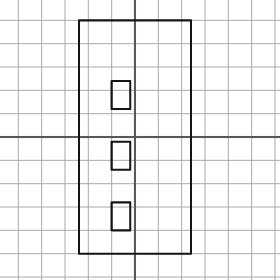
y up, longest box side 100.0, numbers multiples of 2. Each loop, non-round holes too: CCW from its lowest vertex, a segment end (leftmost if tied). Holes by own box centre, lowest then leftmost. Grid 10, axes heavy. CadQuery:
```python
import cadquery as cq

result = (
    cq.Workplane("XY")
    .moveTo(-24.0, -50.0)
    .lineTo(24.0, -50.0)
    .lineTo(24.0, 50.0)
    .lineTo(-24.0, 50.0)
    .close()
    .moveTo(-10.0, -40.0)
    .lineTo(-2.0, -40.0)
    .lineTo(-2.0, -28.0)
    .lineTo(-10.0, -28.0)
    .close()
    .moveTo(-10.0, -14.0)
    .lineTo(-2.0, -14.0)
    .lineTo(-2.0, -2.0)
    .lineTo(-10.0, -2.0)
    .close()
    .moveTo(-10.0, 12.0)
    .lineTo(-2.0, 12.0)
    .lineTo(-2.0, 24.0)
    .lineTo(-10.0, 24.0)
    .close()
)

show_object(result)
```